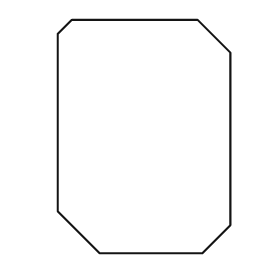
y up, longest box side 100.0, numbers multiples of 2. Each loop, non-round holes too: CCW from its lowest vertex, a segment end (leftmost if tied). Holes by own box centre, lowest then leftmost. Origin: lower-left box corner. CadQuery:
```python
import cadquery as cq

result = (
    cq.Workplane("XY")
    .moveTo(18.0, 0.0)
    .lineTo(62.0, 0.0)
    .lineTo(74.0, 12.0)
    .lineTo(74.0, 86.0)
    .lineTo(60.0, 100.0)
    .lineTo(6.0, 100.0)
    .lineTo(0.0, 94.0)
    .lineTo(0.0, 18.0)
    .close()
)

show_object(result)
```